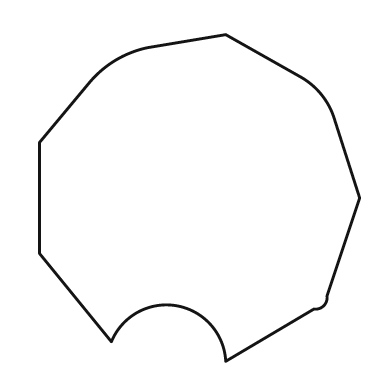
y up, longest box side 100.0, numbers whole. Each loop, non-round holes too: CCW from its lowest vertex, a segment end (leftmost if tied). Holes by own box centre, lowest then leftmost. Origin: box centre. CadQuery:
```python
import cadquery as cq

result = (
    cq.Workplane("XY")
    .moveTo(8.0, -50.0)
    .lineTo(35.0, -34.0)
    .threePointArc((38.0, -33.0), (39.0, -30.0))
    .lineTo(49.0, 0.0)
    .lineTo(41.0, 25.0)
    .threePointArc((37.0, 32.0), (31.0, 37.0))
    .lineTo(8.0, 50.0)
    .lineTo(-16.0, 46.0)
    .threePointArc((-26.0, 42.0), (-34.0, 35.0))
    .lineTo(-49.0, 17.0)
    .lineTo(-49.0, -17.0)
    .lineTo(-27.0, -44.0)
    .threePointArc((-7.0, -33.0), (8.0, -50.0))
    .close()
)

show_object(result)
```